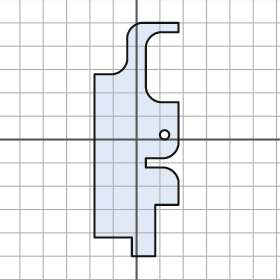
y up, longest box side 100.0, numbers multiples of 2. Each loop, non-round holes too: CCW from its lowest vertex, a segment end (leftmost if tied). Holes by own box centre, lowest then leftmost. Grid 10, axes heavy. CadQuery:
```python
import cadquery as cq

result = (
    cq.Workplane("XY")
    .moveTo(-2.0, -50.0)
    .lineTo(8.0, -50.0)
    .lineTo(8.0, -28.0)
    .lineTo(18.0, -28.0)
    .lineTo(18.0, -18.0)
    .threePointArc((16.0, -14.0), (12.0, -12.0))
    .lineTo(4.0, -12.0)
    .lineTo(4.0, -8.0)
    .lineTo(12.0, -8.0)
    .threePointArc((16.0, -6.0), (18.0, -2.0))
    .lineTo(18.0, 16.0)
    .lineTo(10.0, 16.0)
    .threePointArc((6.0, 18.0), (4.0, 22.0))
    .lineTo(4.0, 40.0)
    .threePointArc((6.0, 44.0), (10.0, 46.0))
    .lineTo(18.0, 46.0)
    .lineTo(18.0, 50.0)
    .lineTo(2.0, 50.0)
    .threePointArc((-2.0, 48.0), (-4.0, 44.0))
    .lineTo(-4.0, 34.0)
    .threePointArc((-6.0, 30.0), (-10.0, 28.0))
    .lineTo(-18.0, 28.0)
    .lineTo(-18.0, -42.0)
    .lineTo(-2.0, -42.0)
    .close()
    .moveTo(12.0, 2.0)
    .circle(2.0)
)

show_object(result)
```